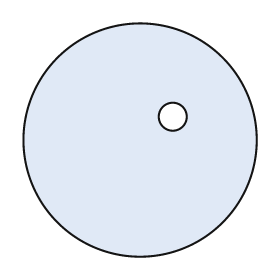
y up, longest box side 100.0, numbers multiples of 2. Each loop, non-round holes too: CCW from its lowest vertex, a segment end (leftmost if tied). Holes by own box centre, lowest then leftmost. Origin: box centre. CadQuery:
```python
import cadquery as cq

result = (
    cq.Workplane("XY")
    .moveTo(0.0, 0.0)
    .circle(50.0)
    .moveTo(14.0, 10.0)
    .circle(6.0)
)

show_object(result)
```